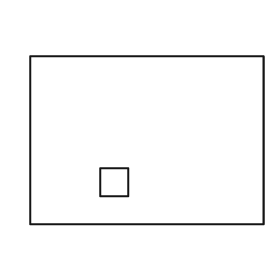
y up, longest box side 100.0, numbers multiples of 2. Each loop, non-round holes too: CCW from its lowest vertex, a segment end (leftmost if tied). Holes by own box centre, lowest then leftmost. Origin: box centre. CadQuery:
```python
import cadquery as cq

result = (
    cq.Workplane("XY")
    .moveTo(-50.0, -36.0)
    .lineTo(50.0, -36.0)
    .lineTo(50.0, 36.0)
    .lineTo(-50.0, 36.0)
    .close()
    .moveTo(-20.0, -24.0)
    .lineTo(-8.0, -24.0)
    .lineTo(-8.0, -12.0)
    .lineTo(-20.0, -12.0)
    .close()
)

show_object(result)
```